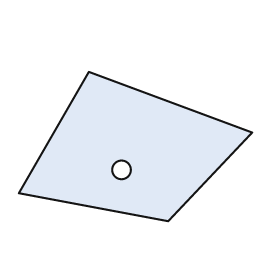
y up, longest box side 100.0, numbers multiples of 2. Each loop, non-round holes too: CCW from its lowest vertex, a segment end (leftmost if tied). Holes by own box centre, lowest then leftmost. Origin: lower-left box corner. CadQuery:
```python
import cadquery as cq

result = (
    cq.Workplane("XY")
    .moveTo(64.0, 0.0)
    .lineTo(100.0, 38.0)
    .lineTo(30.0, 64.0)
    .lineTo(0.0, 12.0)
    .close()
    .moveTo(44.0, 22.0)
    .circle(4.0)
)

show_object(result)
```